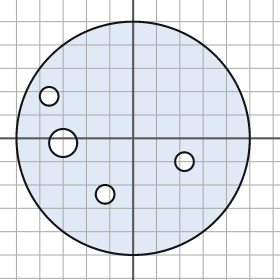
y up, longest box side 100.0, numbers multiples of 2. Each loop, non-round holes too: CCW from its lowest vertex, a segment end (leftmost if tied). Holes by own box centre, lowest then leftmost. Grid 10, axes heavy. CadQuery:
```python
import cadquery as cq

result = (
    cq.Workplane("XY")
    .moveTo(0.0, 0.0)
    .circle(50.0)
    .moveTo(-12.0, -24.0)
    .circle(4.0)
    .moveTo(22.0, -10.0)
    .circle(4.0)
    .moveTo(-30.0, -2.0)
    .circle(6.0)
    .moveTo(-36.0, 18.0)
    .circle(4.0)
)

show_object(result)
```